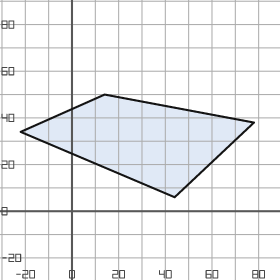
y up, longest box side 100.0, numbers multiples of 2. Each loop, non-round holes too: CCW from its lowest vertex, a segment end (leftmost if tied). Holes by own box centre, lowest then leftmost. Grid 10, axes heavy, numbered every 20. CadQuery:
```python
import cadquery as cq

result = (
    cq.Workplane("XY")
    .moveTo(44.0, 6.0)
    .lineTo(78.0, 38.0)
    .lineTo(14.0, 50.0)
    .lineTo(-22.0, 34.0)
    .close()
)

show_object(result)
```